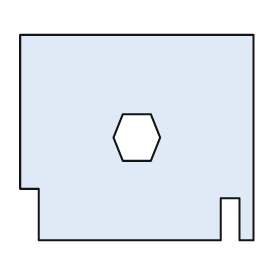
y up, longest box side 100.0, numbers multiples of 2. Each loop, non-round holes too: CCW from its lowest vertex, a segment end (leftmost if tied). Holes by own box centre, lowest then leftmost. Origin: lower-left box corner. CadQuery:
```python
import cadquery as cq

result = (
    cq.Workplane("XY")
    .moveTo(8.0, 0.0)
    .lineTo(86.0, 0.0)
    .lineTo(86.0, 18.0)
    .lineTo(94.0, 18.0)
    .lineTo(94.0, 0.0)
    .lineTo(100.0, 0.0)
    .lineTo(100.0, 88.0)
    .lineTo(0.0, 88.0)
    .lineTo(0.0, 22.0)
    .lineTo(8.0, 22.0)
    .close()
    .moveTo(44.0, 34.0)
    .lineTo(56.0, 34.0)
    .lineTo(60.0, 44.0)
    .lineTo(56.0, 54.0)
    .lineTo(44.0, 54.0)
    .lineTo(40.0, 44.0)
    .close()
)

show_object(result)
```